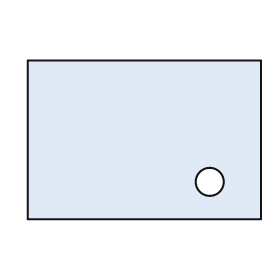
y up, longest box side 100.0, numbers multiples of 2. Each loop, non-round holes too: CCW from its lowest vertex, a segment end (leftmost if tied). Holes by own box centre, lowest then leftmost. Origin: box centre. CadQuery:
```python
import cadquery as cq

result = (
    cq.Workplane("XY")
    .moveTo(-50.0, -34.0)
    .lineTo(50.0, -34.0)
    .lineTo(50.0, 34.0)
    .lineTo(-50.0, 34.0)
    .close()
    .moveTo(28.0, -18.0)
    .circle(6.0)
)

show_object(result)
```